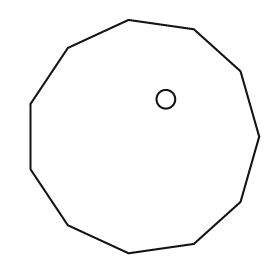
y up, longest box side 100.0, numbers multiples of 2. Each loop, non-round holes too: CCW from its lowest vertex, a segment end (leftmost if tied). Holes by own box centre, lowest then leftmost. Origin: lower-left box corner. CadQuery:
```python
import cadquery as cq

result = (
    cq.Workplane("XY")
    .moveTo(42.0, 0.0)
    .lineTo(70.0, 4.0)
    .lineTo(90.0, 22.0)
    .lineTo(98.0, 50.0)
    .lineTo(90.0, 78.0)
    .lineTo(70.0, 96.0)
    .lineTo(42.0, 100.0)
    .lineTo(16.0, 88.0)
    .lineTo(0.0, 64.0)
    .lineTo(0.0, 36.0)
    .lineTo(16.0, 12.0)
    .close()
    .moveTo(58.0, 66.0)
    .circle(4.0)
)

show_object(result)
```